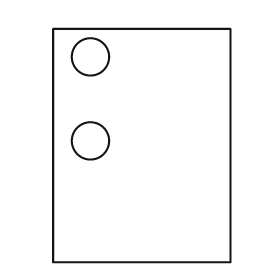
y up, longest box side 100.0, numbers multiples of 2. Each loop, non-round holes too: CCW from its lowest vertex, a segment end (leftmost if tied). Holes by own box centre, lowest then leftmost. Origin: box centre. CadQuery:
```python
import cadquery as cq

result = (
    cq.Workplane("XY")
    .moveTo(-38.0, -50.0)
    .lineTo(38.0, -50.0)
    .lineTo(38.0, 50.0)
    .lineTo(-38.0, 50.0)
    .close()
    .moveTo(-22.0, 2.0)
    .circle(8.0)
    .moveTo(-22.0, 38.0)
    .circle(8.0)
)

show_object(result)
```